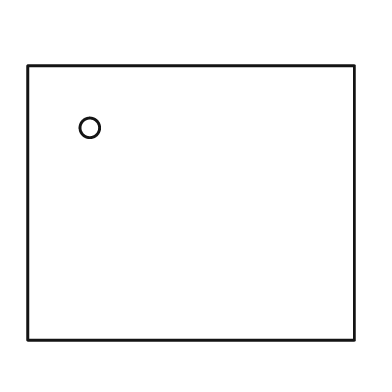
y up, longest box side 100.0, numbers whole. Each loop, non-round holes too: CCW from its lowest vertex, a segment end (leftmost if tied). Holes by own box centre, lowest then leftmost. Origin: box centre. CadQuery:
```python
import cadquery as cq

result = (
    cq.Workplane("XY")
    .moveTo(-50.0, -42.0)
    .lineTo(50.0, -42.0)
    .lineTo(50.0, 42.0)
    .lineTo(-50.0, 42.0)
    .close()
    .moveTo(-31.0, 23.0)
    .circle(3.0)
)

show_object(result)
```